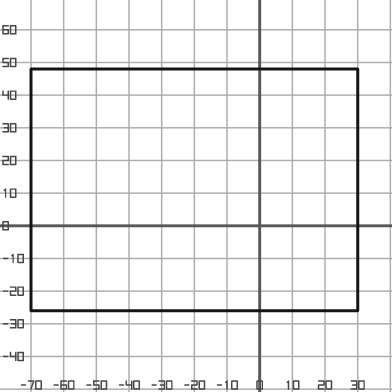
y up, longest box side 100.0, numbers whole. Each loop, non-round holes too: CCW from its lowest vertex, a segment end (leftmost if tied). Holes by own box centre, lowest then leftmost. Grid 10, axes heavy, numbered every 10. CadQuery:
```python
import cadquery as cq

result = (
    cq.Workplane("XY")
    .moveTo(-70.0, -26.0)
    .lineTo(30.0, -26.0)
    .lineTo(30.0, 48.0)
    .lineTo(-70.0, 48.0)
    .close()
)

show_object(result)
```